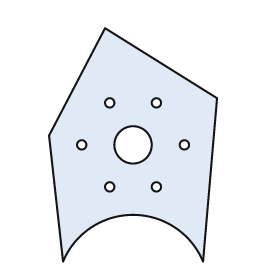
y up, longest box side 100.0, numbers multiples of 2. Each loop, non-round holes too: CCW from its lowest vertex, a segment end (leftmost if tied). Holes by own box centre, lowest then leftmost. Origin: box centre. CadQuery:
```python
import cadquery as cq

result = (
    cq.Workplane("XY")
    .moveTo(-30.0, -50.0)
    .threePointArc((0.0, -30.0), (30.0, -50.0))
    .lineTo(36.0, 20.0)
    .lineTo(-12.0, 50.0)
    .lineTo(-36.0, 4.0)
    .close()
    .moveTo(-10.0, -18.0)
    .circle(2.0)
    .moveTo(10.0, -18.0)
    .circle(2.0)
    .moveTo(-22.0, 0.0)
    .circle(2.0)
    .moveTo(0.0, 0.0)
    .circle(8.0)
    .moveTo(22.0, 0.0)
    .circle(2.0)
    .moveTo(-10.0, 18.0)
    .circle(2.0)
    .moveTo(10.0, 18.0)
    .circle(2.0)
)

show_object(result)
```